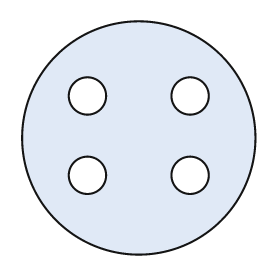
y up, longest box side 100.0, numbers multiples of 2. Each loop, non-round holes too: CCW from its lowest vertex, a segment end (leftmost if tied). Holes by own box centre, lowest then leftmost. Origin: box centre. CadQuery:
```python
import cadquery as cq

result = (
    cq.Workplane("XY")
    .moveTo(0.0, 0.0)
    .circle(50.0)
    .moveTo(-22.0, -16.0)
    .circle(8.0)
    .moveTo(22.0, -16.0)
    .circle(8.0)
    .moveTo(-22.0, 18.0)
    .circle(8.0)
    .moveTo(22.0, 18.0)
    .circle(8.0)
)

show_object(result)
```